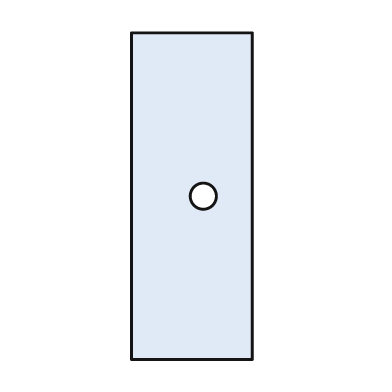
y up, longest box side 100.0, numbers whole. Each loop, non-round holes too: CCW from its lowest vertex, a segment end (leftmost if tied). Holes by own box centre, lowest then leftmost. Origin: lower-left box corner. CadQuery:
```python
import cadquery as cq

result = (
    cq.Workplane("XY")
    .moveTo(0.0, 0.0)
    .lineTo(37.0, 0.0)
    .lineTo(37.0, 100.0)
    .lineTo(0.0, 100.0)
    .close()
    .moveTo(22.0, 50.0)
    .circle(4.0)
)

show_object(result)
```